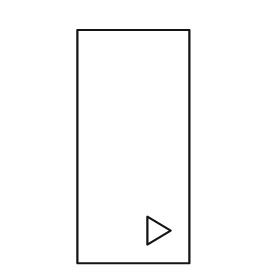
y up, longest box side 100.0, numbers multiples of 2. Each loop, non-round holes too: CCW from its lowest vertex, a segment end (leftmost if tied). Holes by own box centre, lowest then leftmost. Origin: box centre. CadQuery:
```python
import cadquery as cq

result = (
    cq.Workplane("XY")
    .moveTo(-24.0, -50.0)
    .lineTo(24.0, -50.0)
    .lineTo(24.0, 50.0)
    .lineTo(-24.0, 50.0)
    .close()
    .moveTo(6.0, -42.0)
    .lineTo(16.0, -36.0)
    .lineTo(6.0, -30.0)
    .close()
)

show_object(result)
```